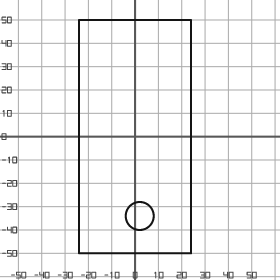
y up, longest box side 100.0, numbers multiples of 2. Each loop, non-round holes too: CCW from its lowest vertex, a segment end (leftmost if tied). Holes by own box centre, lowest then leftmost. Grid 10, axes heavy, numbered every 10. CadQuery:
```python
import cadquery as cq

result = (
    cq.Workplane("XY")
    .moveTo(-24.0, -50.0)
    .lineTo(24.0, -50.0)
    .lineTo(24.0, 50.0)
    .lineTo(-24.0, 50.0)
    .close()
    .moveTo(2.0, -34.0)
    .circle(6.0)
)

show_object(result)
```